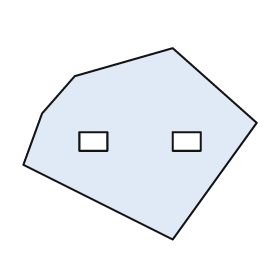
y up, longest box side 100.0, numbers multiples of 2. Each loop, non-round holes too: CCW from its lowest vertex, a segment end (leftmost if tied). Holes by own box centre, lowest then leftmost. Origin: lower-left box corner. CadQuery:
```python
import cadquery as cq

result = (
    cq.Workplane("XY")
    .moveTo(64.0, 0.0)
    .lineTo(100.0, 50.0)
    .lineTo(64.0, 82.0)
    .lineTo(22.0, 70.0)
    .lineTo(8.0, 54.0)
    .lineTo(0.0, 32.0)
    .close()
    .moveTo(24.0, 38.0)
    .lineTo(36.0, 38.0)
    .lineTo(36.0, 46.0)
    .lineTo(24.0, 46.0)
    .close()
    .moveTo(64.0, 38.0)
    .lineTo(76.0, 38.0)
    .lineTo(76.0, 46.0)
    .lineTo(64.0, 46.0)
    .close()
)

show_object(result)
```